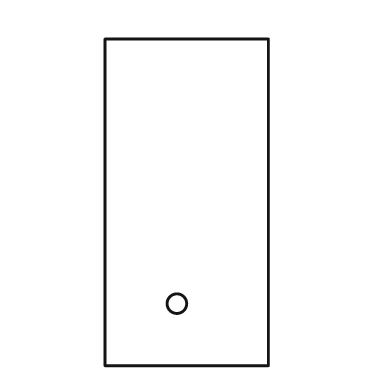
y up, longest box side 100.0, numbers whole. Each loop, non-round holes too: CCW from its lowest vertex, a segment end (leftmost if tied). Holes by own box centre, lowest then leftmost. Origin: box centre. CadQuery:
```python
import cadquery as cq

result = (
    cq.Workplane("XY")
    .moveTo(-25.0, -50.0)
    .lineTo(25.0, -50.0)
    .lineTo(25.0, 50.0)
    .lineTo(-25.0, 50.0)
    .close()
    .moveTo(-3.0, -31.0)
    .circle(3.0)
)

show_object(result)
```